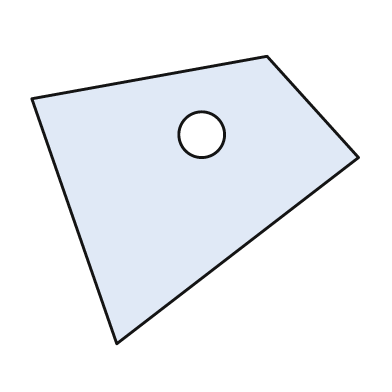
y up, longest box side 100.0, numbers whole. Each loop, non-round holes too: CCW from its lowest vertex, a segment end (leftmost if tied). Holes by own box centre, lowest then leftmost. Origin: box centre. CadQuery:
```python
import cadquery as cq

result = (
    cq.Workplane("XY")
    .moveTo(-24.0, -44.0)
    .lineTo(50.0, 13.0)
    .lineTo(22.0, 44.0)
    .lineTo(-50.0, 31.0)
    .close()
    .moveTo(2.0, 20.0)
    .circle(7.0)
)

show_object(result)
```